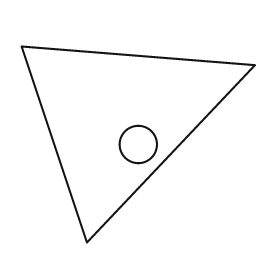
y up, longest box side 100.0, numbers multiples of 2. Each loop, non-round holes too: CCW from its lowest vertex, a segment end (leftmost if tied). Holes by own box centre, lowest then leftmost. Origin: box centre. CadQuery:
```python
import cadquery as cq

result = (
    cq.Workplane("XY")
    .moveTo(-22.0, -42.0)
    .lineTo(50.0, 34.0)
    .lineTo(-50.0, 42.0)
    .close()
    .moveTo(0.0, 0.0)
    .circle(8.0)
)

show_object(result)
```